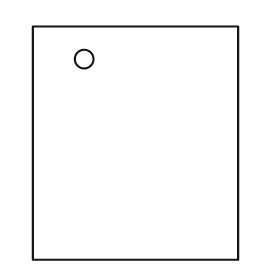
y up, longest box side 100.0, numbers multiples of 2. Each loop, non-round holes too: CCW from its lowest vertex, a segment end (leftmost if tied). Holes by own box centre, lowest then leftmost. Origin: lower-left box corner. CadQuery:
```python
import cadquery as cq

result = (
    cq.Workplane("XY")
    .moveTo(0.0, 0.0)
    .lineTo(88.0, 0.0)
    .lineTo(88.0, 100.0)
    .lineTo(0.0, 100.0)
    .close()
    .moveTo(22.0, 86.0)
    .circle(4.0)
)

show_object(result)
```